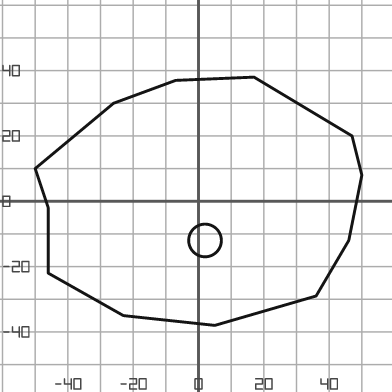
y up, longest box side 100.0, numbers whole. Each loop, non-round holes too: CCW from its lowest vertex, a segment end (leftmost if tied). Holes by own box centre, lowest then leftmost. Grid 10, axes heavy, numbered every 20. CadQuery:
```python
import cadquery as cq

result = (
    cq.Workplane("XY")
    .moveTo(5.0, -38.0)
    .lineTo(36.0, -29.0)
    .lineTo(46.0, -12.0)
    .lineTo(50.0, 8.0)
    .lineTo(47.0, 20.0)
    .lineTo(17.0, 38.0)
    .lineTo(-7.0, 37.0)
    .lineTo(-26.0, 30.0)
    .lineTo(-50.0, 10.0)
    .lineTo(-46.0, -2.0)
    .lineTo(-46.0, -22.0)
    .lineTo(-23.0, -35.0)
    .close()
    .moveTo(2.0, -12.0)
    .circle(5.0)
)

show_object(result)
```